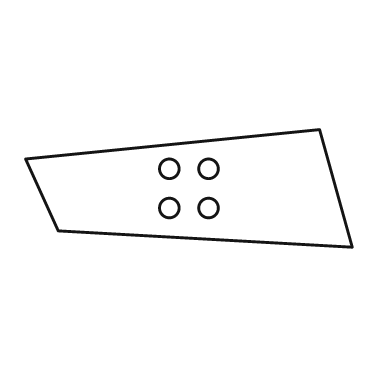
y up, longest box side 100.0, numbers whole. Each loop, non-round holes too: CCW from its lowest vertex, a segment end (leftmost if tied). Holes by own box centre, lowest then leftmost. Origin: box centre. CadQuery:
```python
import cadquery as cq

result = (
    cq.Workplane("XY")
    .moveTo(50.0, -18.0)
    .lineTo(40.0, 18.0)
    .lineTo(-50.0, 9.0)
    .lineTo(-40.0, -13.0)
    .close()
    .moveTo(-6.0, -6.0)
    .circle(3.0)
    .moveTo(6.0, -6.0)
    .circle(3.0)
    .moveTo(-6.0, 6.0)
    .circle(3.0)
    .moveTo(6.0, 6.0)
    .circle(3.0)
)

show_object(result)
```